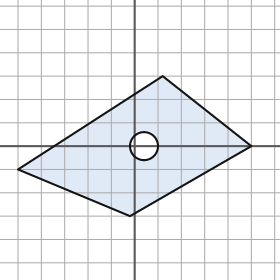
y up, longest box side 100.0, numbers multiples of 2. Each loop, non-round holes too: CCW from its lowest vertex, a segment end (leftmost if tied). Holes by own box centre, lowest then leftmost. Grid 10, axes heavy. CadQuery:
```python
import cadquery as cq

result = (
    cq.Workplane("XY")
    .moveTo(-2.0, -30.0)
    .lineTo(50.0, 0.0)
    .lineTo(12.0, 30.0)
    .lineTo(-50.0, -10.0)
    .close()
    .moveTo(4.0, 0.0)
    .circle(6.0)
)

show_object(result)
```